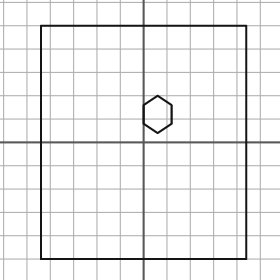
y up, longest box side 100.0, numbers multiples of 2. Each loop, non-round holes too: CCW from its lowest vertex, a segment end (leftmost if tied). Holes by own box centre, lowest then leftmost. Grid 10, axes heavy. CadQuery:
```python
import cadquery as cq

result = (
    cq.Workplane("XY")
    .moveTo(-44.0, -50.0)
    .lineTo(44.0, -50.0)
    .lineTo(44.0, 50.0)
    .lineTo(-44.0, 50.0)
    .close()
    .moveTo(6.0, 4.0)
    .lineTo(12.0, 8.0)
    .lineTo(12.0, 16.0)
    .lineTo(6.0, 20.0)
    .lineTo(0.0, 16.0)
    .lineTo(0.0, 8.0)
    .close()
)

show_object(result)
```